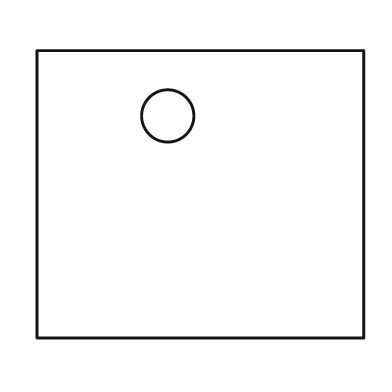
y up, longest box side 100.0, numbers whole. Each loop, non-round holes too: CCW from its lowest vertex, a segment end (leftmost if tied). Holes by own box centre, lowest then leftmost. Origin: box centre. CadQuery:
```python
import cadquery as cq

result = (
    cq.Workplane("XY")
    .moveTo(-50.0, -44.0)
    .lineTo(50.0, -44.0)
    .lineTo(50.0, 44.0)
    .lineTo(-50.0, 44.0)
    .close()
    .moveTo(-10.0, 24.0)
    .circle(8.0)
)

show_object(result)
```